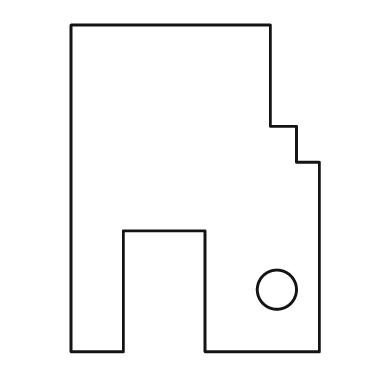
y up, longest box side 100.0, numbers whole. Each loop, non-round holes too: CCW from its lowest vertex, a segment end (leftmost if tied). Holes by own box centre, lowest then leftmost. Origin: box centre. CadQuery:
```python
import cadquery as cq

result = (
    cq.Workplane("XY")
    .moveTo(-38.0, -50.0)
    .lineTo(-22.0, -50.0)
    .lineTo(-22.0, -13.0)
    .lineTo(3.0, -13.0)
    .lineTo(3.0, -50.0)
    .lineTo(38.0, -50.0)
    .lineTo(38.0, 8.0)
    .lineTo(31.0, 8.0)
    .lineTo(31.0, 19.0)
    .lineTo(23.0, 19.0)
    .lineTo(23.0, 50.0)
    .lineTo(-38.0, 50.0)
    .close()
    .moveTo(25.0, -31.0)
    .circle(6.0)
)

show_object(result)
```